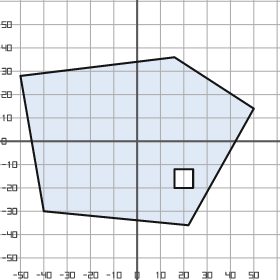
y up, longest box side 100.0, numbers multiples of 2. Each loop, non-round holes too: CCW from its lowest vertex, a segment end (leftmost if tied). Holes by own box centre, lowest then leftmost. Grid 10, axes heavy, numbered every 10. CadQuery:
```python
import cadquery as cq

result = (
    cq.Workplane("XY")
    .moveTo(22.0, -36.0)
    .lineTo(50.0, 14.0)
    .lineTo(16.0, 36.0)
    .lineTo(-50.0, 28.0)
    .lineTo(-40.0, -30.0)
    .close()
    .moveTo(16.0, -20.0)
    .lineTo(24.0, -20.0)
    .lineTo(24.0, -12.0)
    .lineTo(16.0, -12.0)
    .close()
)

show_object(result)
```